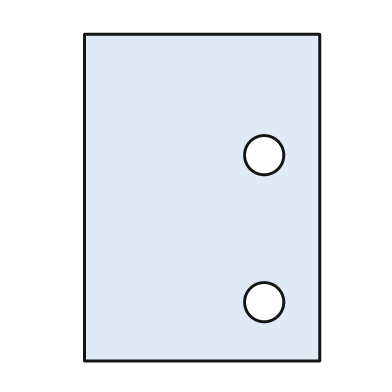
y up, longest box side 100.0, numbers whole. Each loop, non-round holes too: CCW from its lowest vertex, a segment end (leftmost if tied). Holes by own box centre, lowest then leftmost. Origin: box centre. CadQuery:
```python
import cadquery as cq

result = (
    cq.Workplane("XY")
    .moveTo(-36.0, -50.0)
    .lineTo(36.0, -50.0)
    .lineTo(36.0, 50.0)
    .lineTo(-36.0, 50.0)
    .close()
    .moveTo(19.0, -32.0)
    .circle(6.0)
    .moveTo(19.0, 13.0)
    .circle(6.0)
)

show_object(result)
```